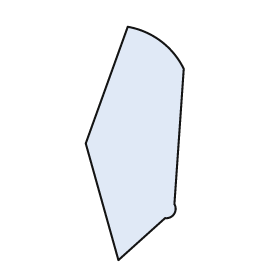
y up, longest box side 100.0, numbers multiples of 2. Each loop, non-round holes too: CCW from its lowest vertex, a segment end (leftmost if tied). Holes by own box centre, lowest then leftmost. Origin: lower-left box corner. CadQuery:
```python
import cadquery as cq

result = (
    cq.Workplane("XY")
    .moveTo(14.0, 0.0)
    .lineTo(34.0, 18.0)
    .threePointArc((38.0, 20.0), (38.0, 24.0))
    .lineTo(42.0, 82.0)
    .threePointArc((32.0, 94.0), (18.0, 100.0))
    .lineTo(0.0, 50.0)
    .close()
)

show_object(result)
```